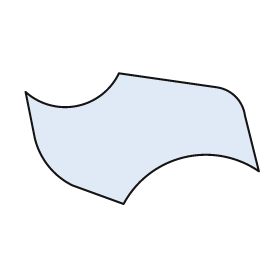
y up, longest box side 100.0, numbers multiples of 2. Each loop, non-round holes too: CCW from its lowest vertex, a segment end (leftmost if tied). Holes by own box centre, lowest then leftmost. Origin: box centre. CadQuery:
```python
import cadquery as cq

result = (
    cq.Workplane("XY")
    .moveTo(-8.0, -28.0)
    .threePointArc((18.0, -8.0), (50.0, -14.0))
    .lineTo(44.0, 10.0)
    .threePointArc((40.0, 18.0), (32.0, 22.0))
    .lineTo(-10.0, 28.0)
    .threePointArc((-28.0, 14.0), (-50.0, 20.0))
    .lineTo(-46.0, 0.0)
    .threePointArc((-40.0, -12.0), (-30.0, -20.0))
    .close()
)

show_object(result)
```